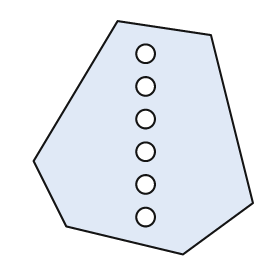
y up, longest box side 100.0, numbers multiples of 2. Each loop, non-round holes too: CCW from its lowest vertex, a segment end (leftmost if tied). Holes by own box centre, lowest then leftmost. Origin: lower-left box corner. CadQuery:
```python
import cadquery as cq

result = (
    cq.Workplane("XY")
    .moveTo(64.0, 0.0)
    .lineTo(94.0, 22.0)
    .lineTo(76.0, 94.0)
    .lineTo(36.0, 100.0)
    .lineTo(0.0, 40.0)
    .lineTo(14.0, 12.0)
    .close()
    .moveTo(48.0, 16.0)
    .circle(4.0)
    .moveTo(48.0, 30.0)
    .circle(4.0)
    .moveTo(48.0, 44.0)
    .circle(4.0)
    .moveTo(48.0, 58.0)
    .circle(4.0)
    .moveTo(48.0, 72.0)
    .circle(4.0)
    .moveTo(48.0, 86.0)
    .circle(4.0)
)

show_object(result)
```